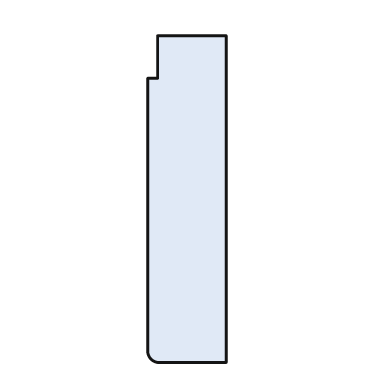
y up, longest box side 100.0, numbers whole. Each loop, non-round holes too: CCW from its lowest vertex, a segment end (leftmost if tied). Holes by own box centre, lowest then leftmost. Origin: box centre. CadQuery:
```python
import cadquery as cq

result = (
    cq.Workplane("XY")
    .moveTo(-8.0, -50.0)
    .lineTo(12.0, -50.0)
    .lineTo(12.0, 50.0)
    .lineTo(-9.0, 50.0)
    .lineTo(-9.0, 37.0)
    .lineTo(-12.0, 37.0)
    .lineTo(-12.0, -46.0)
    .threePointArc((-11.0, -49.0), (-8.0, -50.0))
    .close()
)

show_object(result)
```